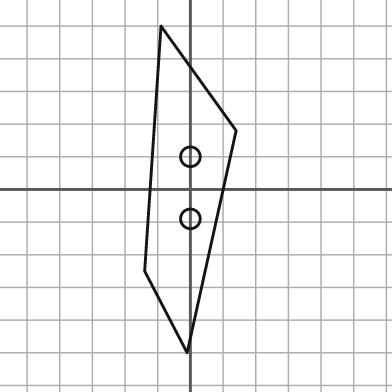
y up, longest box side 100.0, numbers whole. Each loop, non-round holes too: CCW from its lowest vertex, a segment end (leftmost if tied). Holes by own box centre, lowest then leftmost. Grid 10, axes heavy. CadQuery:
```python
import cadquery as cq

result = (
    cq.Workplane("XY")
    .moveTo(-1.0, -50.0)
    .lineTo(14.0, 18.0)
    .lineTo(-9.0, 50.0)
    .lineTo(-14.0, -25.0)
    .close()
    .moveTo(0.0, -9.0)
    .circle(3.0)
    .moveTo(0.0, 10.0)
    .circle(3.0)
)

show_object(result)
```